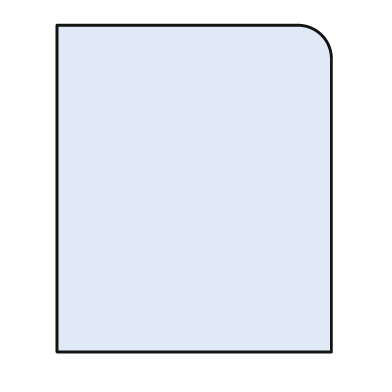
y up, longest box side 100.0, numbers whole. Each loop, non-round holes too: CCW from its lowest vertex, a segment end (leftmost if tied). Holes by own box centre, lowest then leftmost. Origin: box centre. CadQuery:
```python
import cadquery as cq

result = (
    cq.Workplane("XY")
    .moveTo(-42.0, -50.0)
    .lineTo(42.0, -50.0)
    .lineTo(42.0, 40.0)
    .threePointArc((39.0, 47.0), (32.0, 50.0))
    .lineTo(-42.0, 50.0)
    .close()
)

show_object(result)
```